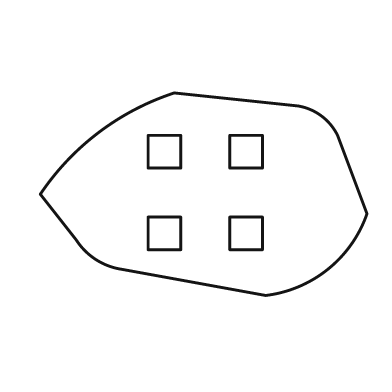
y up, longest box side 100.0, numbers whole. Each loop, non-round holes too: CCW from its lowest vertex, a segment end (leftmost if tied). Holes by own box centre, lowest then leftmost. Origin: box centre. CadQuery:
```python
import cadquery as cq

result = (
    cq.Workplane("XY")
    .moveTo(19.0, -31.0)
    .threePointArc((38.0, -23.0), (50.0, -6.0))
    .lineTo(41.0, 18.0)
    .threePointArc((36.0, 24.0), (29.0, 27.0))
    .lineTo(-9.0, 31.0)
    .threePointArc((-32.0, 19.0), (-50.0, 0.0))
    .lineTo(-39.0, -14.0)
    .threePointArc((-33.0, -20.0), (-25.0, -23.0))
    .close()
    .moveTo(-17.0, -17.0)
    .lineTo(-7.0, -17.0)
    .lineTo(-7.0, -7.0)
    .lineTo(-17.0, -7.0)
    .close()
    .moveTo(8.0, -17.0)
    .lineTo(18.0, -17.0)
    .lineTo(18.0, -7.0)
    .lineTo(8.0, -7.0)
    .close()
    .moveTo(-17.0, 8.0)
    .lineTo(-7.0, 8.0)
    .lineTo(-7.0, 18.0)
    .lineTo(-17.0, 18.0)
    .close()
    .moveTo(8.0, 8.0)
    .lineTo(18.0, 8.0)
    .lineTo(18.0, 18.0)
    .lineTo(8.0, 18.0)
    .close()
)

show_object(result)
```